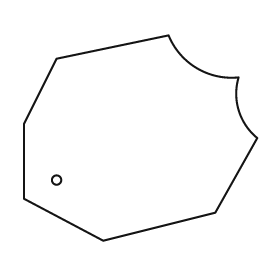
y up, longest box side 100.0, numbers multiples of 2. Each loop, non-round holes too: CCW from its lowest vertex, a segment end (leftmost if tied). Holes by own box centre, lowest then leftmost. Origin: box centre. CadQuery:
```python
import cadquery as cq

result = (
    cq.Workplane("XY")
    .moveTo(-16.0, -44.0)
    .lineTo(32.0, -32.0)
    .lineTo(50.0, 0.0)
    .threePointArc((42.0, 12.0), (42.0, 26.0))
    .threePointArc((24.0, 30.0), (12.0, 44.0))
    .lineTo(-36.0, 34.0)
    .lineTo(-50.0, 6.0)
    .lineTo(-50.0, -26.0)
    .close()
    .moveTo(-36.0, -18.0)
    .circle(2.0)
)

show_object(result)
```